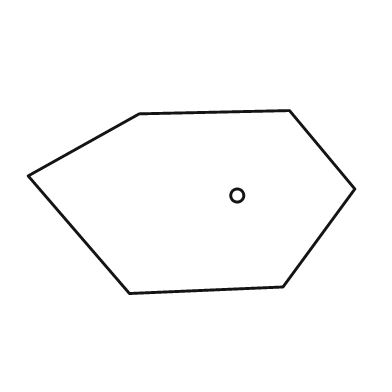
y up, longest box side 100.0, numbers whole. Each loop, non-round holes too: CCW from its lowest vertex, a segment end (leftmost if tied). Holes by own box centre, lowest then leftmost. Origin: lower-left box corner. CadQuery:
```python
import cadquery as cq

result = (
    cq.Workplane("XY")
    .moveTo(31.0, 0.0)
    .lineTo(78.0, 2.0)
    .lineTo(100.0, 32.0)
    .lineTo(80.0, 56.0)
    .lineTo(34.0, 55.0)
    .lineTo(0.0, 36.0)
    .close()
    .moveTo(64.0, 30.0)
    .circle(2.0)
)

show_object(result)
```